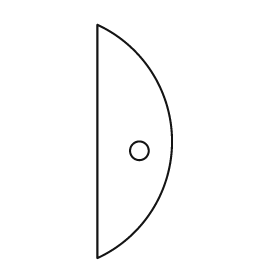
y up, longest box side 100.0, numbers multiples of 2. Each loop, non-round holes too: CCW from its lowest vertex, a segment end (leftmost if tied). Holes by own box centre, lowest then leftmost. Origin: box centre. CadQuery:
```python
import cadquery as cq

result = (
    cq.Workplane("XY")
    .moveTo(-16.0, -50.0)
    .threePointArc((16.0, 0.0), (-16.0, 50.0))
    .close()
    .moveTo(2.0, -4.0)
    .circle(4.0)
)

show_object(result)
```